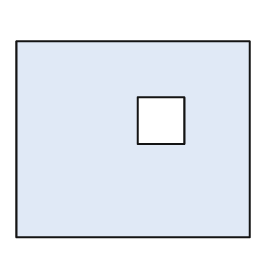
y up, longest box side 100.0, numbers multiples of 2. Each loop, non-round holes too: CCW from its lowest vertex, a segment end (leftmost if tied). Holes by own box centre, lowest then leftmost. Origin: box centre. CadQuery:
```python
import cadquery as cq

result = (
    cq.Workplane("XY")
    .moveTo(-50.0, -42.0)
    .lineTo(50.0, -42.0)
    .lineTo(50.0, 42.0)
    .lineTo(-50.0, 42.0)
    .close()
    .moveTo(2.0, -2.0)
    .lineTo(22.0, -2.0)
    .lineTo(22.0, 18.0)
    .lineTo(2.0, 18.0)
    .close()
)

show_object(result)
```